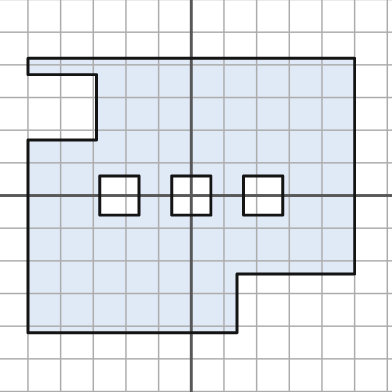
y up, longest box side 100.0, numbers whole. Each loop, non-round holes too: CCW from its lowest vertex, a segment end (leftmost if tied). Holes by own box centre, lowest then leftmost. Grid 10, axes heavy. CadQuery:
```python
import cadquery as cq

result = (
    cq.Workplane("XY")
    .moveTo(-50.0, -42.0)
    .lineTo(14.0, -42.0)
    .lineTo(14.0, -24.0)
    .lineTo(50.0, -24.0)
    .lineTo(50.0, 42.0)
    .lineTo(-50.0, 42.0)
    .lineTo(-50.0, 37.0)
    .lineTo(-29.0, 37.0)
    .lineTo(-29.0, 17.0)
    .lineTo(-50.0, 17.0)
    .close()
    .moveTo(-28.0, -6.0)
    .lineTo(-16.0, -6.0)
    .lineTo(-16.0, 6.0)
    .lineTo(-28.0, 6.0)
    .close()
    .moveTo(-6.0, -6.0)
    .lineTo(6.0, -6.0)
    .lineTo(6.0, 6.0)
    .lineTo(-6.0, 6.0)
    .close()
    .moveTo(16.0, -6.0)
    .lineTo(28.0, -6.0)
    .lineTo(28.0, 6.0)
    .lineTo(16.0, 6.0)
    .close()
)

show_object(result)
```